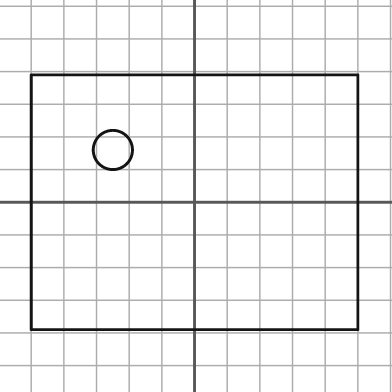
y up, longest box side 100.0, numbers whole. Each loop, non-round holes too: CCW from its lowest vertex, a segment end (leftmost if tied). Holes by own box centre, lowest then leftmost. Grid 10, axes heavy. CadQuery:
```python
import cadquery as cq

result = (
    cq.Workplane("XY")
    .moveTo(-50.0, -39.0)
    .lineTo(50.0, -39.0)
    .lineTo(50.0, 39.0)
    .lineTo(-50.0, 39.0)
    .close()
    .moveTo(-25.0, 16.0)
    .circle(6.0)
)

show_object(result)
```